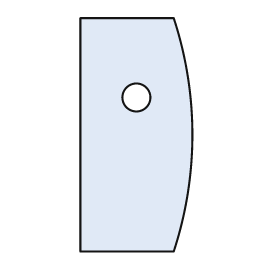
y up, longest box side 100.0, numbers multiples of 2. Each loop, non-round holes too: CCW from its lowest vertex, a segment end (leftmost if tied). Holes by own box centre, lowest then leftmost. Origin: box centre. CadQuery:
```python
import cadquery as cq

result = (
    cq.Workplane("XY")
    .moveTo(-24.0, -50.0)
    .lineTo(16.0, -50.0)
    .threePointArc((24.0, 0.0), (16.0, 50.0))
    .lineTo(-24.0, 50.0)
    .close()
    .moveTo(0.0, 16.0)
    .circle(6.0)
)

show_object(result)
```